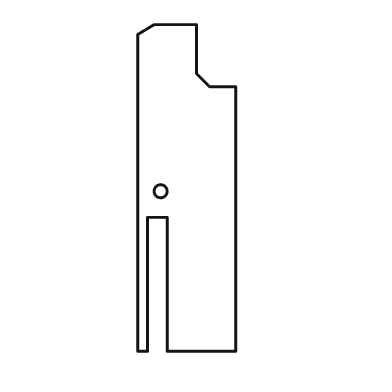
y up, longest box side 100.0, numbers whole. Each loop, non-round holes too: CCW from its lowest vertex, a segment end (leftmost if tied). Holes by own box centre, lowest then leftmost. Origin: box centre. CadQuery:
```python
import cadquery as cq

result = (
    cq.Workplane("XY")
    .moveTo(-15.0, -50.0)
    .lineTo(-12.0, -50.0)
    .lineTo(-12.0, -9.0)
    .lineTo(-6.0, -9.0)
    .lineTo(-6.0, -50.0)
    .lineTo(15.0, -50.0)
    .lineTo(15.0, 31.0)
    .lineTo(7.0, 31.0)
    .lineTo(3.0, 35.0)
    .lineTo(3.0, 50.0)
    .lineTo(-10.0, 50.0)
    .lineTo(-15.0, 47.0)
    .close()
    .moveTo(-8.0, -1.0)
    .circle(2.0)
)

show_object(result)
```